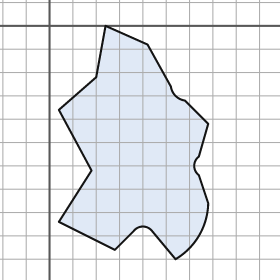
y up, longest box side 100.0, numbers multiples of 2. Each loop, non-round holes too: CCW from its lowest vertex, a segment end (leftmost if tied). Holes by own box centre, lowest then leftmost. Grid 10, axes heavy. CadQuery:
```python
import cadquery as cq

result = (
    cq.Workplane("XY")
    .moveTo(54.0, -100.0)
    .threePointArc((64.0, -90.0), (68.0, -76.0))
    .lineTo(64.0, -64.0)
    .threePointArc((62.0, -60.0), (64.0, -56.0))
    .lineTo(68.0, -42.0)
    .lineTo(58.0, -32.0)
    .threePointArc((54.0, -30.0), (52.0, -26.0))
    .lineTo(42.0, -8.0)
    .lineTo(24.0, 0.0)
    .lineTo(20.0, -22.0)
    .lineTo(4.0, -36.0)
    .lineTo(18.0, -62.0)
    .lineTo(4.0, -84.0)
    .lineTo(28.0, -96.0)
    .lineTo(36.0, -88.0)
    .threePointArc((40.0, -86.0), (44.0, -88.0))
    .close()
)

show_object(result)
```